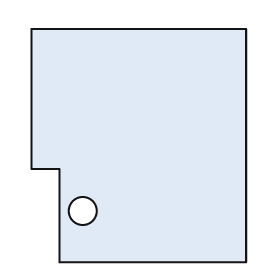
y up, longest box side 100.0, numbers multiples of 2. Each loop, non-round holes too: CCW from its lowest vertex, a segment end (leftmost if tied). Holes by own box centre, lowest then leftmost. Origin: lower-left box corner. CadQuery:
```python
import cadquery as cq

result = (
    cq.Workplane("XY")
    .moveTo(12.0, 0.0)
    .lineTo(92.0, 0.0)
    .lineTo(92.0, 100.0)
    .lineTo(0.0, 100.0)
    .lineTo(0.0, 40.0)
    .lineTo(12.0, 40.0)
    .close()
    .moveTo(22.0, 22.0)
    .circle(6.0)
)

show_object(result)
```